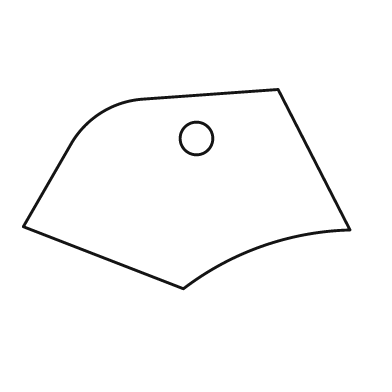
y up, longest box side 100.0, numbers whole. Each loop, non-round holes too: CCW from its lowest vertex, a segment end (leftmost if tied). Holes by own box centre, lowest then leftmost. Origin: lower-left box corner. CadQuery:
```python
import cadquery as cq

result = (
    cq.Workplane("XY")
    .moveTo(49.0, 0.0)
    .threePointArc((73.0, 13.0), (100.0, 18.0))
    .lineTo(78.0, 61.0)
    .lineTo(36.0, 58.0)
    .threePointArc((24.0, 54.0), (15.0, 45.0))
    .lineTo(0.0, 19.0)
    .close()
    .moveTo(53.0, 46.0)
    .circle(5.0)
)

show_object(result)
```